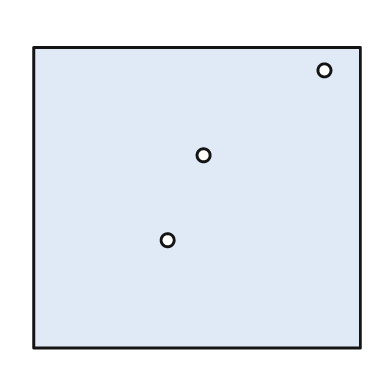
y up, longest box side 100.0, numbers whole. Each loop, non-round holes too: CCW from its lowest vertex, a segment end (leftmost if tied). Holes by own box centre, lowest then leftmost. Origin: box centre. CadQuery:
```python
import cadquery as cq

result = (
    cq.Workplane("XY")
    .moveTo(-50.0, -46.0)
    .lineTo(50.0, -46.0)
    .lineTo(50.0, 46.0)
    .lineTo(-50.0, 46.0)
    .close()
    .moveTo(-9.0, -13.0)
    .circle(2.0)
    .moveTo(2.0, 13.0)
    .circle(2.0)
    .moveTo(39.0, 39.0)
    .circle(2.0)
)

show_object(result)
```